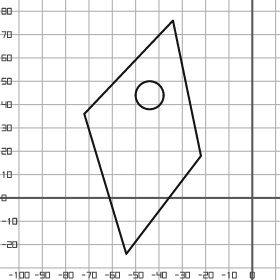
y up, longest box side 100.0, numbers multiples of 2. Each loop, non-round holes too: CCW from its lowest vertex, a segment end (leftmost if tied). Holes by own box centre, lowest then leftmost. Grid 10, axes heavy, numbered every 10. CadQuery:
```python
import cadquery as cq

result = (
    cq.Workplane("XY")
    .moveTo(-54.0, -24.0)
    .lineTo(-22.0, 18.0)
    .lineTo(-34.0, 76.0)
    .lineTo(-72.0, 36.0)
    .close()
    .moveTo(-44.0, 44.0)
    .circle(6.0)
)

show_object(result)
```